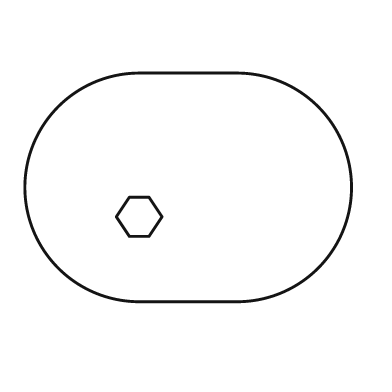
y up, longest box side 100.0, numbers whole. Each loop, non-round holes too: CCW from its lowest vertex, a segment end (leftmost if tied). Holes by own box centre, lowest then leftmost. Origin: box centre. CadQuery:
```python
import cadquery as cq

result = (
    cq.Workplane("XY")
    .moveTo(-15.0, -35.0)
    .lineTo(15.0, -35.0)
    .threePointArc((50.0, 0.0), (15.0, 35.0))
    .lineTo(-15.0, 35.0)
    .threePointArc((-50.0, 0.0), (-15.0, -35.0))
    .close()
    .moveTo(-18.0, -15.0)
    .lineTo(-12.0, -15.0)
    .lineTo(-8.0, -9.0)
    .lineTo(-12.0, -3.0)
    .lineTo(-18.0, -3.0)
    .lineTo(-22.0, -9.0)
    .close()
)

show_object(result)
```